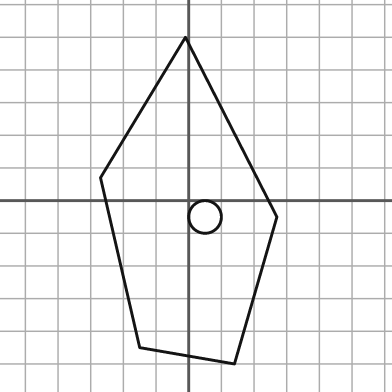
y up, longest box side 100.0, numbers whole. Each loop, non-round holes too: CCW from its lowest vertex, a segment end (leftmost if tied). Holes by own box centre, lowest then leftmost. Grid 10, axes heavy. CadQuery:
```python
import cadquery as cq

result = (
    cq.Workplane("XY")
    .moveTo(14.0, -50.0)
    .lineTo(27.0, -5.0)
    .lineTo(-1.0, 50.0)
    .lineTo(-27.0, 7.0)
    .lineTo(-15.0, -45.0)
    .close()
    .moveTo(5.0, -5.0)
    .circle(5.0)
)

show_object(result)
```